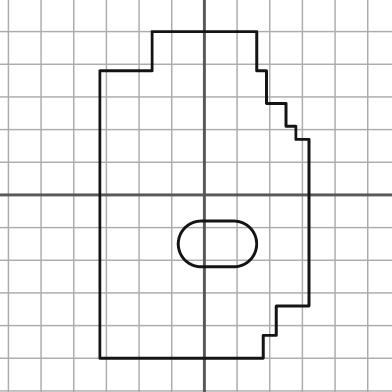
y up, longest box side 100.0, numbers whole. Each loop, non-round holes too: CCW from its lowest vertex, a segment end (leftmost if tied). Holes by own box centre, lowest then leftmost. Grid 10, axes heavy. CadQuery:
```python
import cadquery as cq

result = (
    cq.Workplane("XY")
    .moveTo(-32.0, -50.0)
    .lineTo(18.0, -50.0)
    .lineTo(18.0, -43.0)
    .lineTo(22.0, -43.0)
    .lineTo(22.0, -34.0)
    .lineTo(32.0, -34.0)
    .lineTo(32.0, 17.0)
    .lineTo(28.0, 17.0)
    .lineTo(28.0, 21.0)
    .lineTo(25.0, 21.0)
    .lineTo(25.0, 28.0)
    .lineTo(19.0, 28.0)
    .lineTo(19.0, 38.0)
    .lineTo(16.0, 38.0)
    .lineTo(16.0, 50.0)
    .lineTo(-16.0, 50.0)
    .lineTo(-16.0, 38.0)
    .lineTo(-32.0, 38.0)
    .close()
    .moveTo(-1.0, -22.0)
    .lineTo(9.0, -22.0)
    .threePointArc((16.0, -15.0), (9.0, -8.0))
    .lineTo(-1.0, -8.0)
    .threePointArc((-8.0, -15.0), (-1.0, -22.0))
    .close()
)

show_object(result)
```